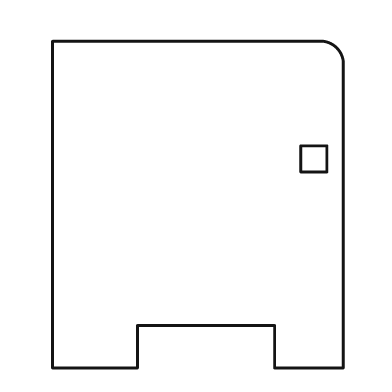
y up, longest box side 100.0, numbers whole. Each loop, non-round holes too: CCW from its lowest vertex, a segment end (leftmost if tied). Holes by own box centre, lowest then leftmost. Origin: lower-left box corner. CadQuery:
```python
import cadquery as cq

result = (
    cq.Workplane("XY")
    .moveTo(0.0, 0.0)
    .lineTo(26.0, 0.0)
    .lineTo(26.0, 13.0)
    .lineTo(68.0, 13.0)
    .lineTo(68.0, 0.0)
    .lineTo(89.0, 0.0)
    .lineTo(89.0, 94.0)
    .threePointArc((87.0, 98.0), (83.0, 100.0))
    .lineTo(0.0, 100.0)
    .close()
    .moveTo(76.0, 60.0)
    .lineTo(84.0, 60.0)
    .lineTo(84.0, 68.0)
    .lineTo(76.0, 68.0)
    .close()
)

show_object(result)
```